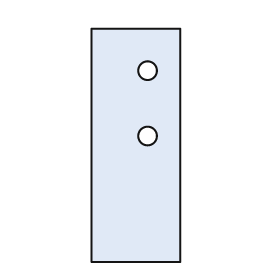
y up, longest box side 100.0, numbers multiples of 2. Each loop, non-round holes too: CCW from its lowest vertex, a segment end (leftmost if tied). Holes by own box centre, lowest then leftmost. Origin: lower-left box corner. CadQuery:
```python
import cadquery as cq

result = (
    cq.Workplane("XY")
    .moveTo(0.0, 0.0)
    .lineTo(38.0, 0.0)
    .lineTo(38.0, 100.0)
    .lineTo(0.0, 100.0)
    .close()
    .moveTo(24.0, 54.0)
    .circle(4.0)
    .moveTo(24.0, 82.0)
    .circle(4.0)
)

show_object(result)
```